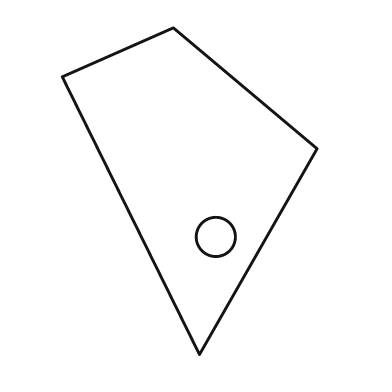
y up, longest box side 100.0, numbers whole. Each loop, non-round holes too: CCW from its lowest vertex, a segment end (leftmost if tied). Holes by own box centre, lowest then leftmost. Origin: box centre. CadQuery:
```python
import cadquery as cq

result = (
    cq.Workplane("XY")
    .moveTo(3.0, -50.0)
    .lineTo(39.0, 13.0)
    .lineTo(-5.0, 50.0)
    .lineTo(-39.0, 35.0)
    .close()
    .moveTo(8.0, -14.0)
    .circle(6.0)
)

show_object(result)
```